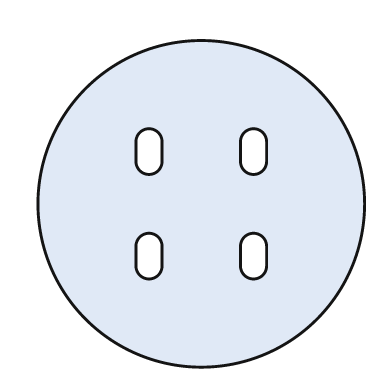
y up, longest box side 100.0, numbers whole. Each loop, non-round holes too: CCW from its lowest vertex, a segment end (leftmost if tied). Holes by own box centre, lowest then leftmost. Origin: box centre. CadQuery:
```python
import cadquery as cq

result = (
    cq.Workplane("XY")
    .moveTo(0.0, 0.0)
    .circle(50.0)
    .moveTo(-20.0, -19.0)
    .threePointArc((-16.0, -23.0), (-12.0, -19.0))
    .lineTo(-12.0, -13.0)
    .threePointArc((-16.0, -9.0), (-20.0, -13.0))
    .close()
    .moveTo(12.0, -19.0)
    .threePointArc((16.0, -23.0), (20.0, -19.0))
    .lineTo(20.0, -13.0)
    .threePointArc((16.0, -9.0), (12.0, -13.0))
    .close()
    .moveTo(-20.0, 13.0)
    .threePointArc((-16.0, 9.0), (-12.0, 13.0))
    .lineTo(-12.0, 19.0)
    .threePointArc((-16.0, 23.0), (-20.0, 19.0))
    .close()
    .moveTo(12.0, 13.0)
    .threePointArc((16.0, 9.0), (20.0, 13.0))
    .lineTo(20.0, 19.0)
    .threePointArc((16.0, 23.0), (12.0, 19.0))
    .close()
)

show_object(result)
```